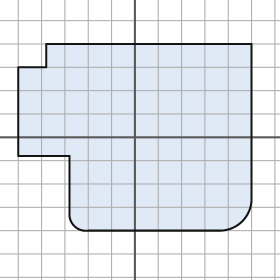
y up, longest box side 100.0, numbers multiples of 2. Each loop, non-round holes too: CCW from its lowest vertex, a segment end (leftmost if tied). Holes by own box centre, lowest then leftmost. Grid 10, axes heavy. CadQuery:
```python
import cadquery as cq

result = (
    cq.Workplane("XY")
    .moveTo(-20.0, -40.0)
    .lineTo(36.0, -40.0)
    .threePointArc((46.0, -36.0), (50.0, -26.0))
    .lineTo(50.0, 40.0)
    .lineTo(-38.0, 40.0)
    .lineTo(-38.0, 30.0)
    .lineTo(-50.0, 30.0)
    .lineTo(-50.0, -8.0)
    .lineTo(-28.0, -8.0)
    .lineTo(-28.0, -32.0)
    .threePointArc((-26.0, -38.0), (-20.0, -40.0))
    .close()
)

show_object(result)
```